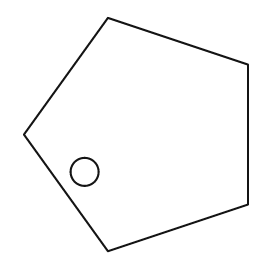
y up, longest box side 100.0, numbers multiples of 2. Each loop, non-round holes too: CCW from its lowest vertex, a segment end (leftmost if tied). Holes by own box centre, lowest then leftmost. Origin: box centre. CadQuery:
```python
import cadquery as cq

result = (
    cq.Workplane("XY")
    .moveTo(-12.0, -50.0)
    .lineTo(48.0, -30.0)
    .lineTo(48.0, 30.0)
    .lineTo(-12.0, 50.0)
    .lineTo(-48.0, 0.0)
    .close()
    .moveTo(-22.0, -16.0)
    .circle(6.0)
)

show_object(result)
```